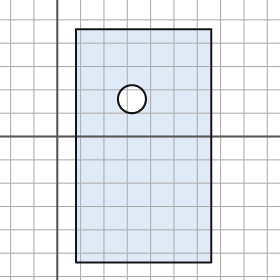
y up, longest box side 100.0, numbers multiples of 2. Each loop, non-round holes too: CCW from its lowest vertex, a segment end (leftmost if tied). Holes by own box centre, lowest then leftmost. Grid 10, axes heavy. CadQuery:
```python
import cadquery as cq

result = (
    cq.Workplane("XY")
    .moveTo(8.0, -54.0)
    .lineTo(66.0, -54.0)
    .lineTo(66.0, 46.0)
    .lineTo(8.0, 46.0)
    .close()
    .moveTo(32.0, 16.0)
    .circle(6.0)
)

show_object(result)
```